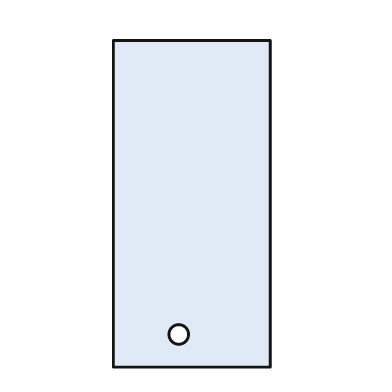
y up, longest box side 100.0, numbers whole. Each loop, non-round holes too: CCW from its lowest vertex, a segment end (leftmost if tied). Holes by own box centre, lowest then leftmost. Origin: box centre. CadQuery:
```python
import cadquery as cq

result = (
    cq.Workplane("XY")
    .moveTo(-24.0, -50.0)
    .lineTo(24.0, -50.0)
    .lineTo(24.0, 50.0)
    .lineTo(-24.0, 50.0)
    .close()
    .moveTo(-4.0, -40.0)
    .circle(3.0)
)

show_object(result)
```